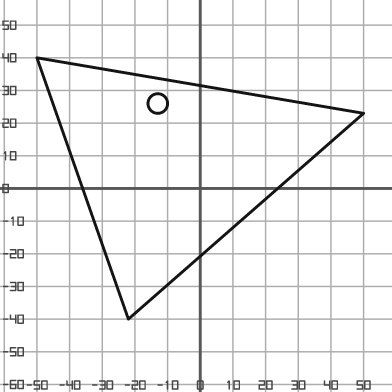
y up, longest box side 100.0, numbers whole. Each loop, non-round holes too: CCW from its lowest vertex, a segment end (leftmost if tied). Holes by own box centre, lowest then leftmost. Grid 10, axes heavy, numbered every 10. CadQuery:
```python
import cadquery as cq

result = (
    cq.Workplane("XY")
    .moveTo(-22.0, -40.0)
    .lineTo(50.0, 23.0)
    .lineTo(-50.0, 40.0)
    .close()
    .moveTo(-13.0, 26.0)
    .circle(3.0)
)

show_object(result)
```